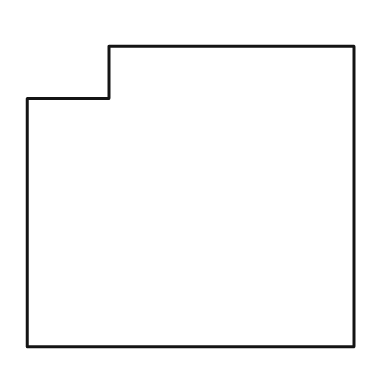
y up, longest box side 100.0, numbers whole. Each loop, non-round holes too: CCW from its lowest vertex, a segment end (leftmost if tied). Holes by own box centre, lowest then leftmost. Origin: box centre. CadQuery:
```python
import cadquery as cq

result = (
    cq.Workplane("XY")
    .moveTo(-50.0, -46.0)
    .lineTo(50.0, -46.0)
    .lineTo(50.0, 46.0)
    .lineTo(-25.0, 46.0)
    .lineTo(-25.0, 30.0)
    .lineTo(-50.0, 30.0)
    .close()
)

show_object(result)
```